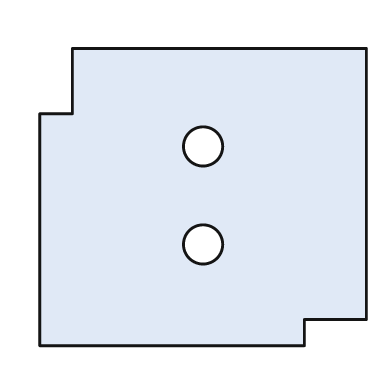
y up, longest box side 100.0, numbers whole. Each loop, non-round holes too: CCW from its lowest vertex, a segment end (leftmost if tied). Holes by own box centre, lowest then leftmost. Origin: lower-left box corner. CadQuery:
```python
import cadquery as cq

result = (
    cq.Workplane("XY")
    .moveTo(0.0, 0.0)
    .lineTo(81.0, 0.0)
    .lineTo(81.0, 8.0)
    .lineTo(100.0, 8.0)
    .lineTo(100.0, 91.0)
    .lineTo(10.0, 91.0)
    .lineTo(10.0, 71.0)
    .lineTo(0.0, 71.0)
    .close()
    .moveTo(50.0, 31.0)
    .circle(6.0)
    .moveTo(50.0, 61.0)
    .circle(6.0)
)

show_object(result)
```